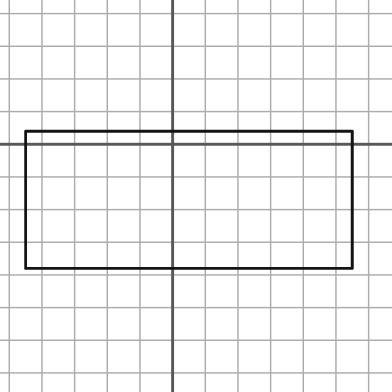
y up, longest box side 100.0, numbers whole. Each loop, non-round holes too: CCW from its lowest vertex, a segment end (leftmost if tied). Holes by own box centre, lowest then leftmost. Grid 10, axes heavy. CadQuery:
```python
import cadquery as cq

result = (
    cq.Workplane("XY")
    .moveTo(-45.0, -38.0)
    .lineTo(55.0, -38.0)
    .lineTo(55.0, 4.0)
    .lineTo(-45.0, 4.0)
    .close()
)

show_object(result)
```